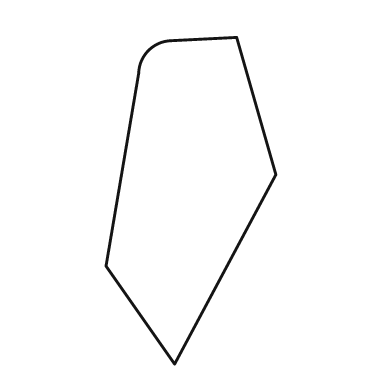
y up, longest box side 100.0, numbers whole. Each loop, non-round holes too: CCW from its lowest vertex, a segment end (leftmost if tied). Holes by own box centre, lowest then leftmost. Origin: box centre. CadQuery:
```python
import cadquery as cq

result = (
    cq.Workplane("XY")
    .moveTo(-5.0, -50.0)
    .lineTo(26.0, 8.0)
    .lineTo(14.0, 50.0)
    .lineTo(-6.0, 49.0)
    .threePointArc((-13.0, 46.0), (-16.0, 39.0))
    .lineTo(-26.0, -20.0)
    .close()
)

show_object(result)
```